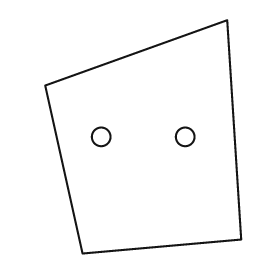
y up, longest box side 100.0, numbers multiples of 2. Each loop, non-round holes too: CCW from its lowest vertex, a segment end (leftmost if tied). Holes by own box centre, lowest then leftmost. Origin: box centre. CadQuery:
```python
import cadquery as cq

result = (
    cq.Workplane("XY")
    .moveTo(-26.0, -50.0)
    .lineTo(42.0, -44.0)
    .lineTo(36.0, 50.0)
    .lineTo(-42.0, 22.0)
    .close()
    .moveTo(-18.0, 0.0)
    .circle(4.0)
    .moveTo(18.0, 0.0)
    .circle(4.0)
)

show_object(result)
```